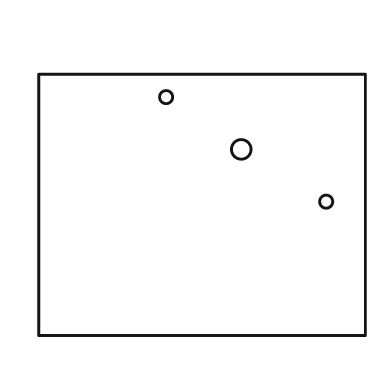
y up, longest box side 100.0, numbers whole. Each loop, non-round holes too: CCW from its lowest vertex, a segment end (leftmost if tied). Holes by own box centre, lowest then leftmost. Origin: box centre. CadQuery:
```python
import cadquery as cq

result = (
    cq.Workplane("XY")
    .moveTo(-50.0, -40.0)
    .lineTo(50.0, -40.0)
    .lineTo(50.0, 40.0)
    .lineTo(-50.0, 40.0)
    .close()
    .moveTo(38.0, 1.0)
    .circle(2.0)
    .moveTo(12.0, 17.0)
    .circle(3.0)
    .moveTo(-11.0, 33.0)
    .circle(2.0)
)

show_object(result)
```